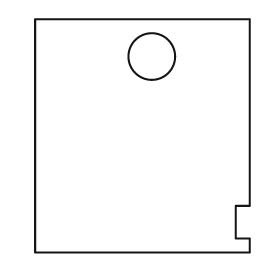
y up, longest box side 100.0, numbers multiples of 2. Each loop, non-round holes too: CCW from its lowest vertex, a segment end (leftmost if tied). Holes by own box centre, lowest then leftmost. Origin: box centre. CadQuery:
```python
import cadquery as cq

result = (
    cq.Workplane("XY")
    .moveTo(-46.0, -50.0)
    .lineTo(46.0, -50.0)
    .lineTo(46.0, -44.0)
    .lineTo(40.0, -44.0)
    .lineTo(40.0, -30.0)
    .lineTo(46.0, -30.0)
    .lineTo(46.0, 50.0)
    .lineTo(-46.0, 50.0)
    .close()
    .moveTo(4.0, 34.0)
    .circle(10.0)
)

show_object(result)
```